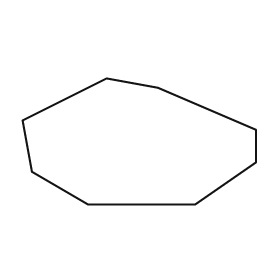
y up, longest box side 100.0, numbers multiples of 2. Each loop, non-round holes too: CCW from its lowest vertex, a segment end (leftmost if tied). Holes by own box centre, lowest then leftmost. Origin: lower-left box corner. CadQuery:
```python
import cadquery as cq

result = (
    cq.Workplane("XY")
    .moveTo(28.0, 0.0)
    .lineTo(74.0, 0.0)
    .lineTo(100.0, 18.0)
    .lineTo(100.0, 32.0)
    .lineTo(58.0, 50.0)
    .lineTo(36.0, 54.0)
    .lineTo(0.0, 36.0)
    .lineTo(4.0, 14.0)
    .close()
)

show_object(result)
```